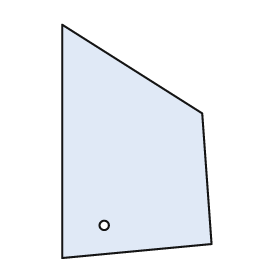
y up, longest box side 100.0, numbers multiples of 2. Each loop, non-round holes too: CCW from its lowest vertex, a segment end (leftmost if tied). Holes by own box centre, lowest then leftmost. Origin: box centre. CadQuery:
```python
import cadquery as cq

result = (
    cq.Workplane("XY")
    .moveTo(-32.0, -50.0)
    .lineTo(32.0, -44.0)
    .lineTo(28.0, 12.0)
    .lineTo(-32.0, 50.0)
    .close()
    .moveTo(-14.0, -36.0)
    .circle(2.0)
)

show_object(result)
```